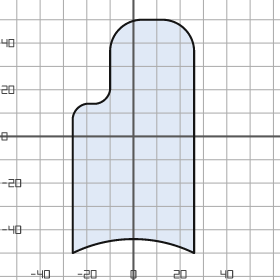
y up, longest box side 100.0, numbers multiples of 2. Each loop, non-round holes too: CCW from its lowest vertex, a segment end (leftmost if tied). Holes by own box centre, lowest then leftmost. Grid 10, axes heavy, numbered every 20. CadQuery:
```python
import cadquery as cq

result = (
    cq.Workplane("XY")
    .moveTo(-26.0, -50.0)
    .threePointArc((0.0, -44.0), (26.0, -50.0))
    .lineTo(26.0, 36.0)
    .threePointArc((22.0, 46.0), (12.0, 50.0))
    .lineTo(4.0, 50.0)
    .threePointArc((-6.0, 46.0), (-10.0, 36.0))
    .lineTo(-10.0, 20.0)
    .threePointArc((-12.0, 16.0), (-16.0, 14.0))
    .lineTo(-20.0, 14.0)
    .threePointArc((-24.0, 12.0), (-26.0, 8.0))
    .close()
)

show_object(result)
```